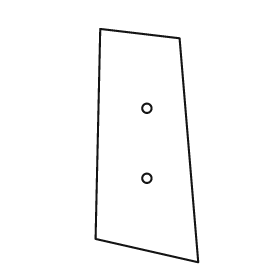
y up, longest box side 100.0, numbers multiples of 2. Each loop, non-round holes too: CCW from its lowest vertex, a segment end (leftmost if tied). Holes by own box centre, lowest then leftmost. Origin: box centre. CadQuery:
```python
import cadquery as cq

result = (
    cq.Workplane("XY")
    .moveTo(22.0, -50.0)
    .lineTo(14.0, 46.0)
    .lineTo(-20.0, 50.0)
    .lineTo(-22.0, -40.0)
    .close()
    .moveTo(0.0, -14.0)
    .circle(2.0)
    .moveTo(0.0, 16.0)
    .circle(2.0)
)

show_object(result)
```